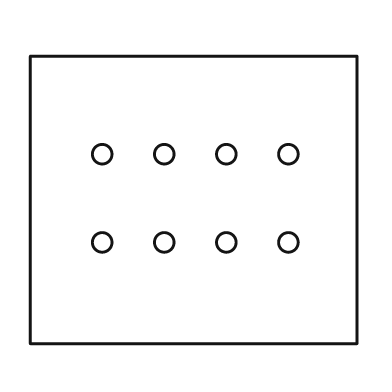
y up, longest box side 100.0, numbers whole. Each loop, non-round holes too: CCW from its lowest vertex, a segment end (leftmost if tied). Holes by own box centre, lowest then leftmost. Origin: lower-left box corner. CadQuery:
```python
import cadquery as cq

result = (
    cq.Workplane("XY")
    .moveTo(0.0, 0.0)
    .lineTo(100.0, 0.0)
    .lineTo(100.0, 88.0)
    .lineTo(0.0, 88.0)
    .close()
    .moveTo(22.0, 31.0)
    .circle(3.0)
    .moveTo(41.0, 31.0)
    .circle(3.0)
    .moveTo(60.0, 31.0)
    .circle(3.0)
    .moveTo(79.0, 31.0)
    .circle(3.0)
    .moveTo(22.0, 58.0)
    .circle(3.0)
    .moveTo(41.0, 58.0)
    .circle(3.0)
    .moveTo(60.0, 58.0)
    .circle(3.0)
    .moveTo(79.0, 58.0)
    .circle(3.0)
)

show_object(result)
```